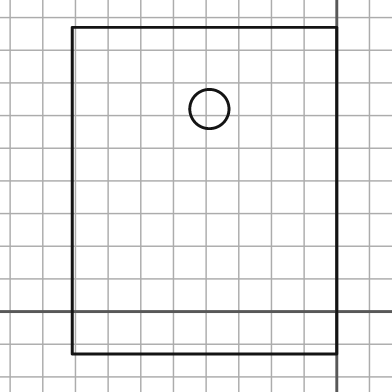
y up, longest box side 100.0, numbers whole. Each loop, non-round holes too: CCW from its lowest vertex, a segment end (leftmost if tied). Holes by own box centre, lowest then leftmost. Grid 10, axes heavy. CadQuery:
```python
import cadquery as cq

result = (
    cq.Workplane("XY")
    .moveTo(-81.0, -13.0)
    .lineTo(0.0, -13.0)
    .lineTo(0.0, 87.0)
    .lineTo(-81.0, 87.0)
    .close()
    .moveTo(-39.0, 62.0)
    .circle(6.0)
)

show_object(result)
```